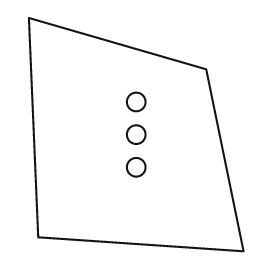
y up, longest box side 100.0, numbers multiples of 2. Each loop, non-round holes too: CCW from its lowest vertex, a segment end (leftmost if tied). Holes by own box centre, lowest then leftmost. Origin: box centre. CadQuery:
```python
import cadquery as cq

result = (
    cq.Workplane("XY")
    .moveTo(46.0, -50.0)
    .lineTo(30.0, 28.0)
    .lineTo(-46.0, 50.0)
    .lineTo(-42.0, -44.0)
    .close()
    .moveTo(0.0, -14.0)
    .circle(4.0)
    .moveTo(0.0, 0.0)
    .circle(4.0)
    .moveTo(0.0, 14.0)
    .circle(4.0)
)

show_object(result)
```